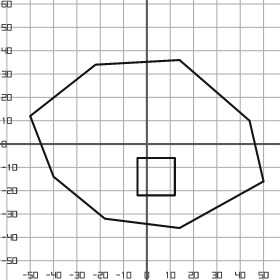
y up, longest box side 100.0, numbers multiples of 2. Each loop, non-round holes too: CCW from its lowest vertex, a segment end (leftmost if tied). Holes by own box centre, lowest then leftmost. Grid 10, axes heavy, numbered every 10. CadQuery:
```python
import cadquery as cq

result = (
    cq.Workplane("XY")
    .moveTo(14.0, -36.0)
    .lineTo(50.0, -16.0)
    .lineTo(44.0, 10.0)
    .lineTo(14.0, 36.0)
    .lineTo(-22.0, 34.0)
    .lineTo(-50.0, 12.0)
    .lineTo(-40.0, -14.0)
    .lineTo(-18.0, -32.0)
    .close()
    .moveTo(-4.0, -22.0)
    .lineTo(12.0, -22.0)
    .lineTo(12.0, -6.0)
    .lineTo(-4.0, -6.0)
    .close()
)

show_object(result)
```